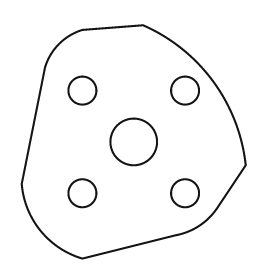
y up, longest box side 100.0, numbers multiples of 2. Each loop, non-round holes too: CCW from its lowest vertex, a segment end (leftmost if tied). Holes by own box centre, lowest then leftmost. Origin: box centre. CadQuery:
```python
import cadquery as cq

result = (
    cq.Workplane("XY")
    .moveTo(-22.0, -50.0)
    .lineTo(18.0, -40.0)
    .threePointArc((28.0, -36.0), (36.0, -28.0))
    .lineTo(48.0, -10.0)
    .threePointArc((34.0, 26.0), (4.0, 50.0))
    .lineTo(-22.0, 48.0)
    .threePointArc((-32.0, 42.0), (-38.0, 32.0))
    .lineTo(-48.0, -18.0)
    .threePointArc((-40.0, -38.0), (-22.0, -50.0))
    .close()
    .moveTo(-22.0, -22.0)
    .circle(6.0)
    .moveTo(22.0, -22.0)
    .circle(6.0)
    .moveTo(0.0, 0.0)
    .circle(10.0)
    .moveTo(-22.0, 22.0)
    .circle(6.0)
    .moveTo(22.0, 22.0)
    .circle(6.0)
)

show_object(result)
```